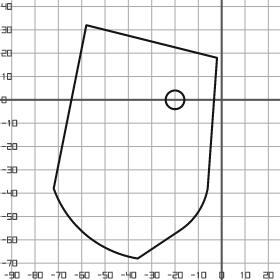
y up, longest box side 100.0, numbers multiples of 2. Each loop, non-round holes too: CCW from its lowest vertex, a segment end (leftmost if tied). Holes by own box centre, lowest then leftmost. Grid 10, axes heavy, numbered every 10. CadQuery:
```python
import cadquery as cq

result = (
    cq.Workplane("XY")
    .moveTo(-36.0, -68.0)
    .lineTo(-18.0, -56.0)
    .threePointArc((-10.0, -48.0), (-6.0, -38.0))
    .lineTo(-2.0, 18.0)
    .lineTo(-58.0, 32.0)
    .lineTo(-72.0, -38.0)
    .threePointArc((-58.0, -58.0), (-36.0, -68.0))
    .close()
    .moveTo(-20.0, 0.0)
    .circle(4.0)
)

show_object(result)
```